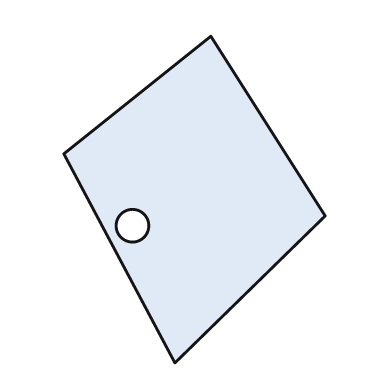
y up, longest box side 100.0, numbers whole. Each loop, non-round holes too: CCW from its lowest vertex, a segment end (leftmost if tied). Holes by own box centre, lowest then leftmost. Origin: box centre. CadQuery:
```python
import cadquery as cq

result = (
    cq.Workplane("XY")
    .moveTo(-6.0, -50.0)
    .lineTo(40.0, -5.0)
    .lineTo(5.0, 50.0)
    .lineTo(-40.0, 14.0)
    .close()
    .moveTo(-19.0, -8.0)
    .circle(5.0)
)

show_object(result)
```